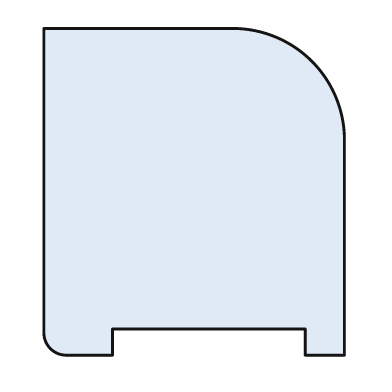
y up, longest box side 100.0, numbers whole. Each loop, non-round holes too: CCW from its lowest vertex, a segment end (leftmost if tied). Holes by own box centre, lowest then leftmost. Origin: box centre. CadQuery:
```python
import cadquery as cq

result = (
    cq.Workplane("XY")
    .moveTo(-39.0, -50.0)
    .lineTo(-25.0, -50.0)
    .lineTo(-25.0, -42.0)
    .lineTo(34.0, -42.0)
    .lineTo(34.0, -50.0)
    .lineTo(46.0, -50.0)
    .lineTo(46.0, 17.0)
    .threePointArc((36.0, 40.0), (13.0, 50.0))
    .lineTo(-46.0, 50.0)
    .lineTo(-46.0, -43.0)
    .threePointArc((-44.0, -48.0), (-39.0, -50.0))
    .close()
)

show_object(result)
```